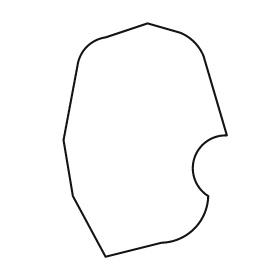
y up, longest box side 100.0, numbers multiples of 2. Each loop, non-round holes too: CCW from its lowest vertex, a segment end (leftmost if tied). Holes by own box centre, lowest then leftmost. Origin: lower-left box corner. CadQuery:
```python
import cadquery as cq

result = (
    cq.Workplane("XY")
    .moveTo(18.0, 0.0)
    .lineTo(42.0, 6.0)
    .threePointArc((56.0, 12.0), (62.0, 26.0))
    .threePointArc((56.0, 42.0), (70.0, 52.0))
    .lineTo(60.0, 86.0)
    .threePointArc((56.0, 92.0), (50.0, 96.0))
    .lineTo(36.0, 100.0)
    .lineTo(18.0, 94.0)
    .threePointArc((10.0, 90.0), (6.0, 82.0))
    .lineTo(0.0, 50.0)
    .lineTo(4.0, 26.0)
    .close()
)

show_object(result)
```